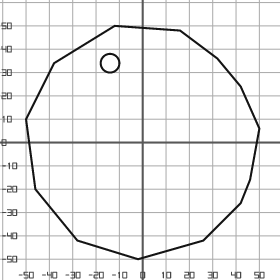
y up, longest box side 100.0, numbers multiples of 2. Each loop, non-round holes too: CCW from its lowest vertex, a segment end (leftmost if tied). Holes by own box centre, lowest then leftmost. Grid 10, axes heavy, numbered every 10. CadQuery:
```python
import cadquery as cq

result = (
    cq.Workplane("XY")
    .moveTo(-2.0, -50.0)
    .lineTo(26.0, -42.0)
    .lineTo(42.0, -26.0)
    .lineTo(46.0, -16.0)
    .lineTo(50.0, 6.0)
    .lineTo(42.0, 24.0)
    .lineTo(32.0, 36.0)
    .lineTo(16.0, 48.0)
    .lineTo(-12.0, 50.0)
    .lineTo(-38.0, 34.0)
    .lineTo(-50.0, 10.0)
    .lineTo(-46.0, -20.0)
    .lineTo(-28.0, -42.0)
    .close()
    .moveTo(-14.0, 34.0)
    .circle(4.0)
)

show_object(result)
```